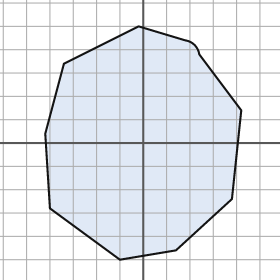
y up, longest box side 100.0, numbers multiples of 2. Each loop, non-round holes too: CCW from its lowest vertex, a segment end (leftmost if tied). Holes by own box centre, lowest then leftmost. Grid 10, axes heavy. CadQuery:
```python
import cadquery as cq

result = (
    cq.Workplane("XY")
    .moveTo(-10.0, -50.0)
    .lineTo(14.0, -46.0)
    .lineTo(38.0, -24.0)
    .lineTo(42.0, 14.0)
    .lineTo(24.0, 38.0)
    .threePointArc((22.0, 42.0), (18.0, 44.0))
    .lineTo(-2.0, 50.0)
    .lineTo(-34.0, 34.0)
    .lineTo(-42.0, 4.0)
    .lineTo(-40.0, -28.0)
    .close()
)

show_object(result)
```